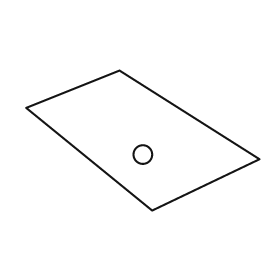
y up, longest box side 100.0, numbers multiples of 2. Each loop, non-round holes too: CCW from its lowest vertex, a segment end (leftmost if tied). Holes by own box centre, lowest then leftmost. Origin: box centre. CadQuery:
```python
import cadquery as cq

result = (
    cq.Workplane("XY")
    .moveTo(4.0, -30.0)
    .lineTo(50.0, -8.0)
    .lineTo(-10.0, 30.0)
    .lineTo(-50.0, 14.0)
    .close()
    .moveTo(0.0, -6.0)
    .circle(4.0)
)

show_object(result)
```